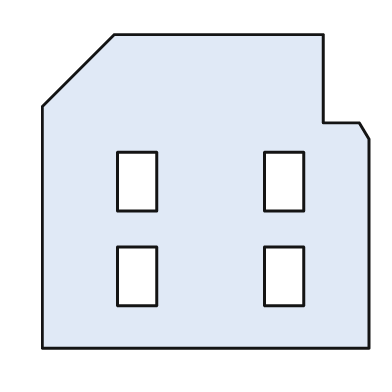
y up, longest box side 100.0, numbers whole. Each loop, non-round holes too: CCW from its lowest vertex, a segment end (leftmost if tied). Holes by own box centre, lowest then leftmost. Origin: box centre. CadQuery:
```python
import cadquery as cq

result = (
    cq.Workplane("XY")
    .moveTo(-50.0, -48.0)
    .lineTo(50.0, -48.0)
    .lineTo(50.0, 16.0)
    .lineTo(47.0, 21.0)
    .lineTo(36.0, 21.0)
    .lineTo(36.0, 48.0)
    .lineTo(-28.0, 48.0)
    .lineTo(-50.0, 26.0)
    .close()
    .moveTo(-27.0, -35.0)
    .lineTo(-15.0, -35.0)
    .lineTo(-15.0, -17.0)
    .lineTo(-27.0, -17.0)
    .close()
    .moveTo(18.0, -35.0)
    .lineTo(30.0, -35.0)
    .lineTo(30.0, -17.0)
    .lineTo(18.0, -17.0)
    .close()
    .moveTo(-27.0, -6.0)
    .lineTo(-15.0, -6.0)
    .lineTo(-15.0, 12.0)
    .lineTo(-27.0, 12.0)
    .close()
    .moveTo(18.0, -6.0)
    .lineTo(30.0, -6.0)
    .lineTo(30.0, 12.0)
    .lineTo(18.0, 12.0)
    .close()
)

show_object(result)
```